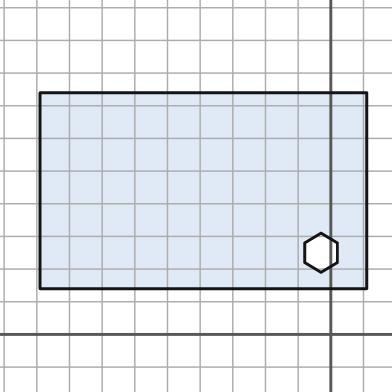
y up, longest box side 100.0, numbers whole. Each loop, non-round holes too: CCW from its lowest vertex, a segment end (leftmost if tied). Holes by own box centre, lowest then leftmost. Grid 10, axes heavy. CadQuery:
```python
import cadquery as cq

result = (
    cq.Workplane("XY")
    .moveTo(-89.0, 14.0)
    .lineTo(11.0, 14.0)
    .lineTo(11.0, 74.0)
    .lineTo(-89.0, 74.0)
    .close()
    .moveTo(-3.0, 19.0)
    .lineTo(2.0, 22.0)
    .lineTo(2.0, 28.0)
    .lineTo(-3.0, 31.0)
    .lineTo(-8.0, 28.0)
    .lineTo(-8.0, 22.0)
    .close()
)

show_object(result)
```